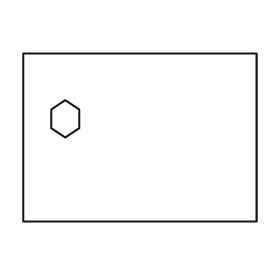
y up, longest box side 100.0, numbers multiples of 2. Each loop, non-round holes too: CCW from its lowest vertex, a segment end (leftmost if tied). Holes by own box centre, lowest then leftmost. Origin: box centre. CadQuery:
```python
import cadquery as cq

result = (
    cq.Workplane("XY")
    .moveTo(-50.0, -36.0)
    .lineTo(50.0, -36.0)
    .lineTo(50.0, 36.0)
    .lineTo(-50.0, 36.0)
    .close()
    .moveTo(-32.0, 0.0)
    .lineTo(-26.0, 4.0)
    .lineTo(-26.0, 12.0)
    .lineTo(-32.0, 16.0)
    .lineTo(-38.0, 12.0)
    .lineTo(-38.0, 4.0)
    .close()
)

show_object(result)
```